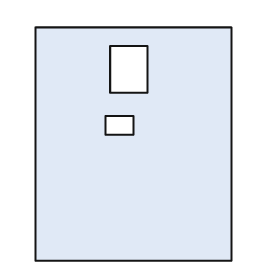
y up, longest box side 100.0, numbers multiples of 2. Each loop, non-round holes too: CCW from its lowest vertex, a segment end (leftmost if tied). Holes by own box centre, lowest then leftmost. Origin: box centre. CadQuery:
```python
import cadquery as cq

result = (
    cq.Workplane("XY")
    .moveTo(-42.0, -50.0)
    .lineTo(42.0, -50.0)
    .lineTo(42.0, 50.0)
    .lineTo(-42.0, 50.0)
    .close()
    .moveTo(-12.0, 4.0)
    .lineTo(0.0, 4.0)
    .lineTo(0.0, 12.0)
    .lineTo(-12.0, 12.0)
    .close()
    .moveTo(-10.0, 22.0)
    .lineTo(6.0, 22.0)
    .lineTo(6.0, 42.0)
    .lineTo(-10.0, 42.0)
    .close()
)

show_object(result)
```